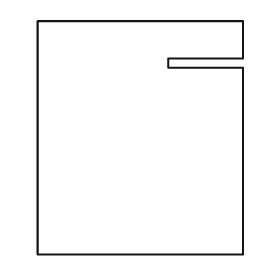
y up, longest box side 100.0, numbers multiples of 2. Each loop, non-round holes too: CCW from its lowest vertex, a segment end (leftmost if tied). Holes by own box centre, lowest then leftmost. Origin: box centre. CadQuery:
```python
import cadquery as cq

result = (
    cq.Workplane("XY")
    .moveTo(-44.0, -50.0)
    .lineTo(44.0, -50.0)
    .lineTo(44.0, 30.0)
    .lineTo(12.0, 30.0)
    .lineTo(12.0, 34.0)
    .lineTo(44.0, 34.0)
    .lineTo(44.0, 50.0)
    .lineTo(-44.0, 50.0)
    .close()
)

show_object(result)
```